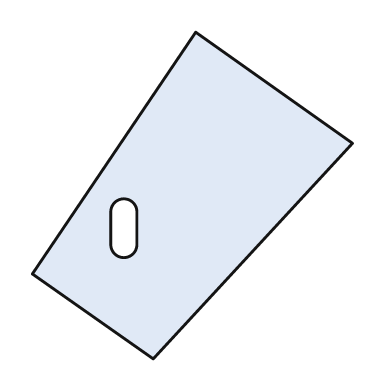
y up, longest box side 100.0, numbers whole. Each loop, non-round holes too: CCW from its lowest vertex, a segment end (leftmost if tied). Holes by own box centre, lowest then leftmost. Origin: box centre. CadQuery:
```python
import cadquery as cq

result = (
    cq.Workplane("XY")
    .moveTo(-12.0, -50.0)
    .lineTo(49.0, 16.0)
    .lineTo(1.0, 50.0)
    .lineTo(-49.0, -24.0)
    .close()
    .moveTo(-25.0, -15.0)
    .threePointArc((-21.0, -19.0), (-17.0, -15.0))
    .lineTo(-17.0, -5.0)
    .threePointArc((-21.0, -1.0), (-25.0, -5.0))
    .close()
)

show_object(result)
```